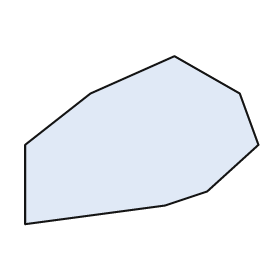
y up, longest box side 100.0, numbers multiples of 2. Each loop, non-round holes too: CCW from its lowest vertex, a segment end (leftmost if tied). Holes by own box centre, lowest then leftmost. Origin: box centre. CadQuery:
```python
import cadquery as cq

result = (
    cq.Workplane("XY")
    .moveTo(-50.0, -36.0)
    .lineTo(10.0, -28.0)
    .lineTo(28.0, -22.0)
    .lineTo(50.0, -2.0)
    .lineTo(42.0, 20.0)
    .lineTo(14.0, 36.0)
    .lineTo(-22.0, 20.0)
    .lineTo(-50.0, -2.0)
    .close()
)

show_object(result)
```